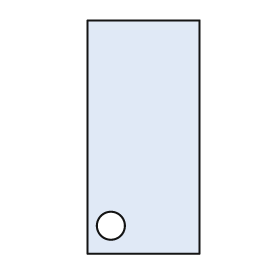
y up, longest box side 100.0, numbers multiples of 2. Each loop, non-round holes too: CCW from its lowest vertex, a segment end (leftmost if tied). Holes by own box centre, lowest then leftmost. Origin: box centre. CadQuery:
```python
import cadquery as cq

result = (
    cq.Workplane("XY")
    .moveTo(-24.0, -50.0)
    .lineTo(24.0, -50.0)
    .lineTo(24.0, 50.0)
    .lineTo(-24.0, 50.0)
    .close()
    .moveTo(-14.0, -38.0)
    .circle(6.0)
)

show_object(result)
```